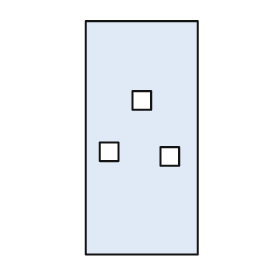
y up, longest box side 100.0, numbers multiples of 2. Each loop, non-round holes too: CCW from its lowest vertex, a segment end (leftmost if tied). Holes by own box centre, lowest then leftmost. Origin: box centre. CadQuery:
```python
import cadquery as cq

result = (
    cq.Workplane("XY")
    .moveTo(-24.0, -50.0)
    .lineTo(24.0, -50.0)
    .lineTo(24.0, 50.0)
    .lineTo(-24.0, 50.0)
    .close()
    .moveTo(8.0, -12.0)
    .lineTo(16.0, -12.0)
    .lineTo(16.0, -4.0)
    .lineTo(8.0, -4.0)
    .close()
    .moveTo(-18.0, -10.0)
    .lineTo(-10.0, -10.0)
    .lineTo(-10.0, -2.0)
    .lineTo(-18.0, -2.0)
    .close()
    .moveTo(-4.0, 12.0)
    .lineTo(4.0, 12.0)
    .lineTo(4.0, 20.0)
    .lineTo(-4.0, 20.0)
    .close()
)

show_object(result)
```